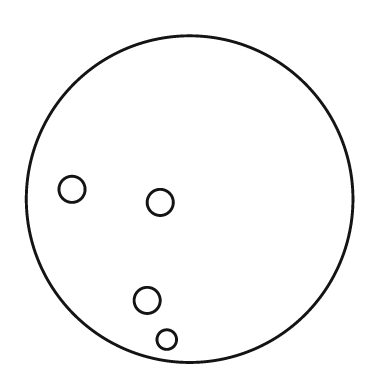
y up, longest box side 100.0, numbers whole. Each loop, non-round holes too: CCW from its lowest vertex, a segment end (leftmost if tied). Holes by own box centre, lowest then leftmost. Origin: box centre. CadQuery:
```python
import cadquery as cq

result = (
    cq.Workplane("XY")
    .moveTo(0.0, 0.0)
    .circle(50.0)
    .moveTo(-7.0, -43.0)
    .circle(3.0)
    .moveTo(-13.0, -31.0)
    .circle(4.0)
    .moveTo(-9.0, -1.0)
    .circle(4.0)
    .moveTo(-36.0, 3.0)
    .circle(4.0)
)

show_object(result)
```